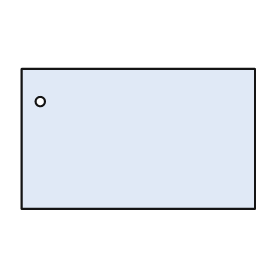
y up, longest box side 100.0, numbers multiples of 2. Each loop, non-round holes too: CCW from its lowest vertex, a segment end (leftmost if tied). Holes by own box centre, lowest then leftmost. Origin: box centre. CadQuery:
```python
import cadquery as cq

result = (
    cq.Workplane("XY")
    .moveTo(-50.0, -30.0)
    .lineTo(50.0, -30.0)
    .lineTo(50.0, 30.0)
    .lineTo(-50.0, 30.0)
    .close()
    .moveTo(-42.0, 16.0)
    .circle(2.0)
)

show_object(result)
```